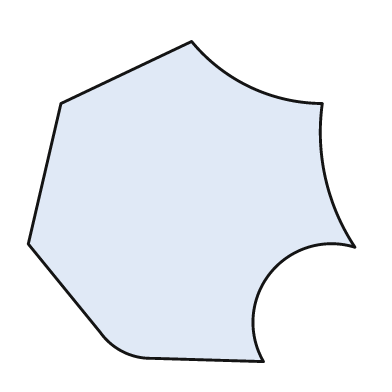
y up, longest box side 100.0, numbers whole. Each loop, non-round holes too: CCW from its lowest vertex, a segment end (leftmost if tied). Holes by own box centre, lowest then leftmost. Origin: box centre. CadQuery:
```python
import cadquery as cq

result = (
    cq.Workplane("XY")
    .moveTo(22.0, -49.0)
    .threePointArc((24.0, -22.0), (50.0, -14.0))
    .threePointArc((41.0, 7.0), (40.0, 30.0))
    .threePointArc((18.0, 35.0), (0.0, 49.0))
    .lineTo(-40.0, 30.0)
    .lineTo(-50.0, -13.0)
    .lineTo(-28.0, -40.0)
    .threePointArc((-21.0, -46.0), (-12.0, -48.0))
    .close()
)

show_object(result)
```